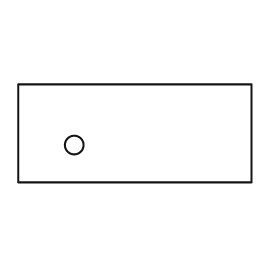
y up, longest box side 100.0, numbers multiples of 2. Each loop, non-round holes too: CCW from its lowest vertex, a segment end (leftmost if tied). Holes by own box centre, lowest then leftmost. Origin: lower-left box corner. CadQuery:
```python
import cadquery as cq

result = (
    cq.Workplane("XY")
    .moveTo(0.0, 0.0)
    .lineTo(100.0, 0.0)
    .lineTo(100.0, 42.0)
    .lineTo(0.0, 42.0)
    .close()
    .moveTo(24.0, 16.0)
    .circle(4.0)
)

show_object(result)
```